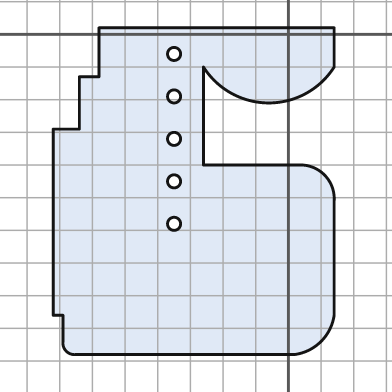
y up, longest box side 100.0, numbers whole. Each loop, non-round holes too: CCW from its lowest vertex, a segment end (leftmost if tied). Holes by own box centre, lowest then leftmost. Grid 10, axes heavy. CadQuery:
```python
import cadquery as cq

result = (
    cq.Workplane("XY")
    .moveTo(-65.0, -98.0)
    .lineTo(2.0, -98.0)
    .threePointArc((10.0, -94.0), (14.0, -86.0))
    .lineTo(14.0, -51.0)
    .threePointArc((11.0, -43.0), (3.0, -40.0))
    .lineTo(-26.0, -40.0)
    .lineTo(-26.0, -10.0)
    .threePointArc((-6.0, -21.0), (14.0, -10.0))
    .lineTo(14.0, 2.0)
    .lineTo(-58.0, 2.0)
    .lineTo(-58.0, -13.0)
    .lineTo(-64.0, -13.0)
    .lineTo(-64.0, -29.0)
    .lineTo(-72.0, -29.0)
    .lineTo(-72.0, -86.0)
    .lineTo(-69.0, -86.0)
    .lineTo(-69.0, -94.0)
    .threePointArc((-68.0, -97.0), (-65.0, -98.0))
    .close()
    .moveTo(-35.0, -58.0)
    .circle(2.0)
    .moveTo(-35.0, -45.0)
    .circle(2.0)
    .moveTo(-35.0, -32.0)
    .circle(2.0)
    .moveTo(-35.0, -19.0)
    .circle(2.0)
    .moveTo(-35.0, -6.0)
    .circle(2.0)
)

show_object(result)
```